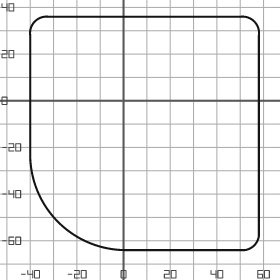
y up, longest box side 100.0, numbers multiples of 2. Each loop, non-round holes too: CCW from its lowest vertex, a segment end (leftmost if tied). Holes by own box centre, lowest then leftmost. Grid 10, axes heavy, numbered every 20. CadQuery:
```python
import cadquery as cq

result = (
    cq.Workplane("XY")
    .moveTo(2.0, -64.0)
    .lineTo(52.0, -64.0)
    .threePointArc((56.0, -62.0), (58.0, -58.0))
    .lineTo(58.0, 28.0)
    .threePointArc((56.0, 34.0), (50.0, 36.0))
    .lineTo(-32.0, 36.0)
    .threePointArc((-38.0, 34.0), (-40.0, 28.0))
    .lineTo(-40.0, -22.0)
    .threePointArc((-28.0, -52.0), (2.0, -64.0))
    .close()
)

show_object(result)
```